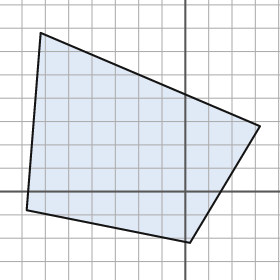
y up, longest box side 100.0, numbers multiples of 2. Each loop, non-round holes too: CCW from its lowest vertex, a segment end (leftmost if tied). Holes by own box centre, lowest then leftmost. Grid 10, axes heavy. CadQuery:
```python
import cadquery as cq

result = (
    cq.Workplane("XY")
    .moveTo(2.0, -22.0)
    .lineTo(32.0, 28.0)
    .lineTo(-62.0, 68.0)
    .lineTo(-68.0, -8.0)
    .close()
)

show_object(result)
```